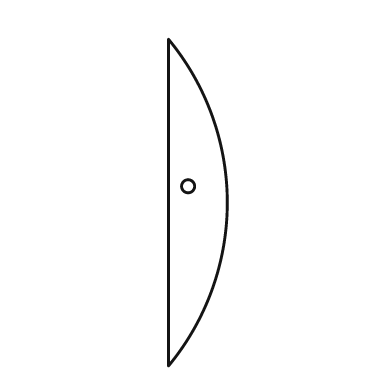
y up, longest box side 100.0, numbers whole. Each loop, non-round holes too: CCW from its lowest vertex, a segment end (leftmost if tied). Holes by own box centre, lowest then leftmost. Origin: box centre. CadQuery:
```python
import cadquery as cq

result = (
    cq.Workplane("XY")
    .moveTo(-9.0, -50.0)
    .threePointArc((9.0, 0.0), (-9.0, 50.0))
    .close()
    .moveTo(-3.0, 5.0)
    .circle(2.0)
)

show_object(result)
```